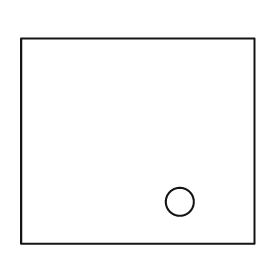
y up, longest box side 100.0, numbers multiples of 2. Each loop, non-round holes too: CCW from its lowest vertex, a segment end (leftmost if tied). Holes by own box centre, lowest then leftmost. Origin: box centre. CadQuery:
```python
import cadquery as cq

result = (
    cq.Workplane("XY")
    .moveTo(-50.0, -44.0)
    .lineTo(50.0, -44.0)
    .lineTo(50.0, 44.0)
    .lineTo(-50.0, 44.0)
    .close()
    .moveTo(18.0, -26.0)
    .circle(6.0)
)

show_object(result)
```